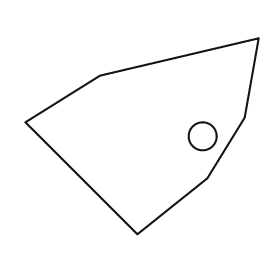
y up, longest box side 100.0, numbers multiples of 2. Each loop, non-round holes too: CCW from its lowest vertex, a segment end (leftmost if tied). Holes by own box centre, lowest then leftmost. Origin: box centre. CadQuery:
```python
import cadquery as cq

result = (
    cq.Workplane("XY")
    .moveTo(-2.0, -42.0)
    .lineTo(28.0, -18.0)
    .lineTo(44.0, 8.0)
    .lineTo(50.0, 42.0)
    .lineTo(-18.0, 26.0)
    .lineTo(-50.0, 6.0)
    .close()
    .moveTo(26.0, 0.0)
    .circle(6.0)
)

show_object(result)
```